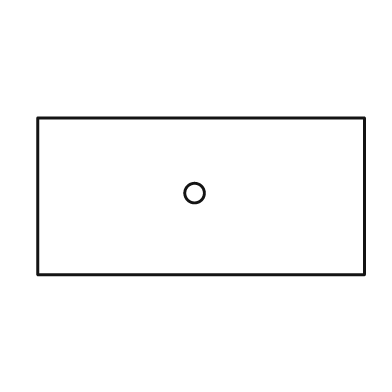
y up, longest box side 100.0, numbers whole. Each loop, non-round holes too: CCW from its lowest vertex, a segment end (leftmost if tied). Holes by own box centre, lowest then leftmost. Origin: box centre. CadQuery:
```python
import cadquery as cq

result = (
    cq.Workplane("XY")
    .moveTo(-50.0, -24.0)
    .lineTo(50.0, -24.0)
    .lineTo(50.0, 24.0)
    .lineTo(-50.0, 24.0)
    .close()
    .moveTo(-2.0, 1.0)
    .circle(3.0)
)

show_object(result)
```